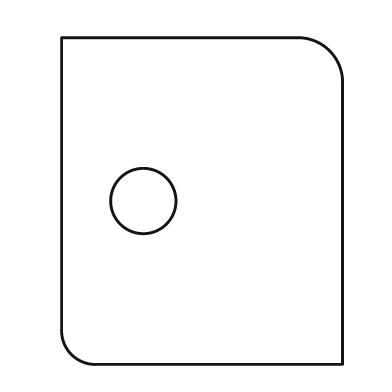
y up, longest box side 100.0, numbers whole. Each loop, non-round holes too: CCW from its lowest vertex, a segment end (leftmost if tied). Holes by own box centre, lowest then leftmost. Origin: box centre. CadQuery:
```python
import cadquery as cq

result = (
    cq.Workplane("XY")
    .moveTo(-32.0, -50.0)
    .lineTo(43.0, -50.0)
    .lineTo(43.0, 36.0)
    .threePointArc((39.0, 46.0), (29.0, 50.0))
    .lineTo(-43.0, 50.0)
    .lineTo(-43.0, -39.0)
    .threePointArc((-40.0, -47.0), (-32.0, -50.0))
    .close()
    .moveTo(-18.0, 0.0)
    .circle(10.0)
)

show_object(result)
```